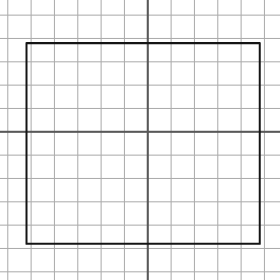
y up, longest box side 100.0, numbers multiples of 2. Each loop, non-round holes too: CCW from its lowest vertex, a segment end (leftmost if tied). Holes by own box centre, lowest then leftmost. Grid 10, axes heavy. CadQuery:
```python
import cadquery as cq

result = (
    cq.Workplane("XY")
    .moveTo(-52.0, -48.0)
    .lineTo(48.0, -48.0)
    .lineTo(48.0, 38.0)
    .lineTo(-52.0, 38.0)
    .close()
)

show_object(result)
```